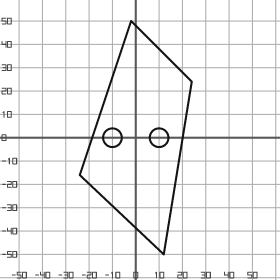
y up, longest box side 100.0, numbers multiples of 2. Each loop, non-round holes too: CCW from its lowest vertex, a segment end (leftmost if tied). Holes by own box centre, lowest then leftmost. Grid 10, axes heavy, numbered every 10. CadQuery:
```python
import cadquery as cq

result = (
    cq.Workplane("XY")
    .moveTo(12.0, -50.0)
    .lineTo(24.0, 24.0)
    .lineTo(-2.0, 50.0)
    .lineTo(-24.0, -16.0)
    .close()
    .moveTo(-10.0, 0.0)
    .circle(4.0)
    .moveTo(10.0, 0.0)
    .circle(4.0)
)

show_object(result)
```